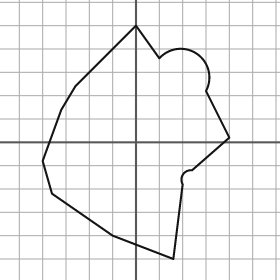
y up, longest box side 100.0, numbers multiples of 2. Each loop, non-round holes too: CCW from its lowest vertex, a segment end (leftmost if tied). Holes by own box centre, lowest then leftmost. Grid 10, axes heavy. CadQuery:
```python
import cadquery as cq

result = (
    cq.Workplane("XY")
    .moveTo(16.0, -50.0)
    .lineTo(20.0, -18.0)
    .threePointArc((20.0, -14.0), (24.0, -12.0))
    .lineTo(40.0, 2.0)
    .lineTo(30.0, 22.0)
    .threePointArc((26.0, 38.0), (10.0, 36.0))
    .lineTo(0.0, 50.0)
    .lineTo(-26.0, 24.0)
    .lineTo(-32.0, 14.0)
    .lineTo(-40.0, -8.0)
    .lineTo(-36.0, -22.0)
    .lineTo(-10.0, -40.0)
    .close()
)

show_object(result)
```